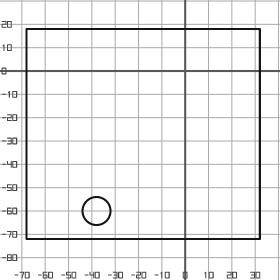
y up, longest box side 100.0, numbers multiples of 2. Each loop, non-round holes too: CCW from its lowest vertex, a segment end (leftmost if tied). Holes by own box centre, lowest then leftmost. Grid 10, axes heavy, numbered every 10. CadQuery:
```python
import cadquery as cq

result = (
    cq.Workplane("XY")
    .moveTo(-68.0, -72.0)
    .lineTo(32.0, -72.0)
    .lineTo(32.0, 18.0)
    .lineTo(-68.0, 18.0)
    .close()
    .moveTo(-38.0, -60.0)
    .circle(6.0)
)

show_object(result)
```